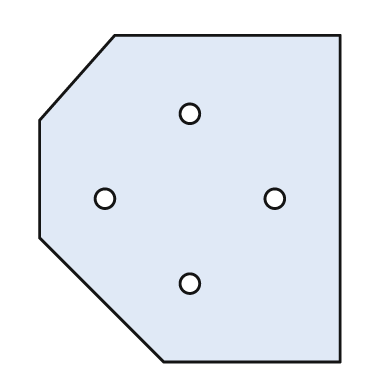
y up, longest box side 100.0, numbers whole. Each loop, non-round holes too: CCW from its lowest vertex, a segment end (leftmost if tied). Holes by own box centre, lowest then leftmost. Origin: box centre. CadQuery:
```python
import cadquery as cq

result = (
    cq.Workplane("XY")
    .moveTo(-8.0, -50.0)
    .lineTo(46.0, -50.0)
    .lineTo(46.0, 50.0)
    .lineTo(-23.0, 50.0)
    .lineTo(-46.0, 24.0)
    .lineTo(-46.0, -12.0)
    .close()
    .moveTo(0.0, -26.0)
    .circle(3.0)
    .moveTo(-26.0, 0.0)
    .circle(3.0)
    .moveTo(26.0, 0.0)
    .circle(3.0)
    .moveTo(0.0, 26.0)
    .circle(3.0)
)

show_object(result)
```